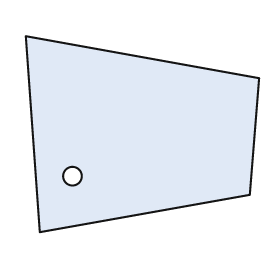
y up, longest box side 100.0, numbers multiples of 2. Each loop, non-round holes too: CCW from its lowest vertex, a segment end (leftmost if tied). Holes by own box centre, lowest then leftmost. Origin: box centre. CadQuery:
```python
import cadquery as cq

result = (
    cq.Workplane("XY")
    .moveTo(-44.0, -42.0)
    .lineTo(46.0, -26.0)
    .lineTo(50.0, 24.0)
    .lineTo(-50.0, 42.0)
    .close()
    .moveTo(-30.0, -18.0)
    .circle(4.0)
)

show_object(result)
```